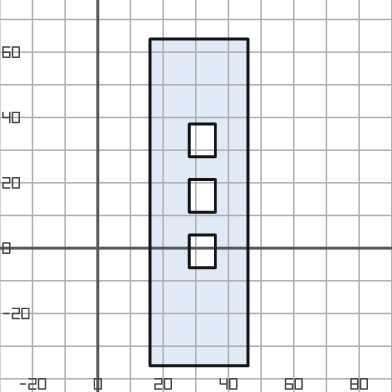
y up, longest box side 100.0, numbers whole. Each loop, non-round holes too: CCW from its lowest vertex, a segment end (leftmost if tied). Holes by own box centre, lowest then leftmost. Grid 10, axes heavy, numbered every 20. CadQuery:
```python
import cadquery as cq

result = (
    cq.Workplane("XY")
    .moveTo(16.0, -36.0)
    .lineTo(46.0, -36.0)
    .lineTo(46.0, 64.0)
    .lineTo(16.0, 64.0)
    .close()
    .moveTo(28.0, -6.0)
    .lineTo(36.0, -6.0)
    .lineTo(36.0, 4.0)
    .lineTo(28.0, 4.0)
    .close()
    .moveTo(28.0, 11.0)
    .lineTo(36.0, 11.0)
    .lineTo(36.0, 21.0)
    .lineTo(28.0, 21.0)
    .close()
    .moveTo(28.0, 28.0)
    .lineTo(36.0, 28.0)
    .lineTo(36.0, 38.0)
    .lineTo(28.0, 38.0)
    .close()
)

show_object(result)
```